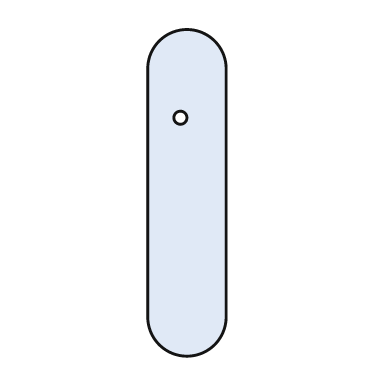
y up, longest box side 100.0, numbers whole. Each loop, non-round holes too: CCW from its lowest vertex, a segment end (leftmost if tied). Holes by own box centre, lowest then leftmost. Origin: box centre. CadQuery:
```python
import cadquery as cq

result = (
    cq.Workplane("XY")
    .moveTo(-12.0, -38.0)
    .threePointArc((0.0, -50.0), (12.0, -38.0))
    .lineTo(12.0, 38.0)
    .threePointArc((0.0, 50.0), (-12.0, 38.0))
    .close()
    .moveTo(-2.0, 23.0)
    .circle(2.0)
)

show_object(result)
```